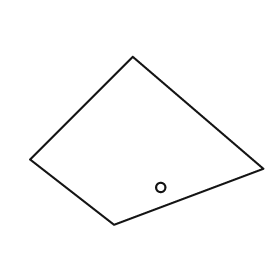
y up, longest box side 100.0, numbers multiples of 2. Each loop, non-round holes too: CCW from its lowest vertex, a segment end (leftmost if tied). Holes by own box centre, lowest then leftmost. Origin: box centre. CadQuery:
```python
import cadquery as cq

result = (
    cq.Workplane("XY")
    .moveTo(-14.0, -36.0)
    .lineTo(50.0, -12.0)
    .lineTo(-6.0, 36.0)
    .lineTo(-50.0, -8.0)
    .close()
    .moveTo(6.0, -20.0)
    .circle(2.0)
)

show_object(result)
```